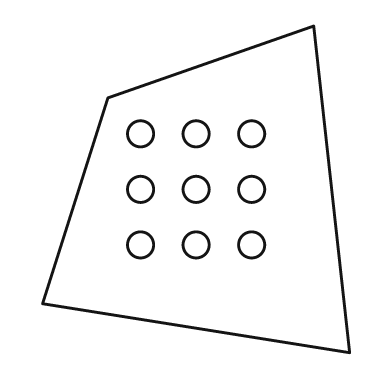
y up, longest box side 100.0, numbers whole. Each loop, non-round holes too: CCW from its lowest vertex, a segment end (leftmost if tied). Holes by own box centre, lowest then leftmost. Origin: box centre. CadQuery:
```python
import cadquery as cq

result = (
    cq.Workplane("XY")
    .moveTo(47.0, -50.0)
    .lineTo(36.0, 50.0)
    .lineTo(-27.0, 28.0)
    .lineTo(-47.0, -35.0)
    .close()
    .moveTo(-17.0, -17.0)
    .circle(4.0)
    .moveTo(0.0, -17.0)
    .circle(4.0)
    .moveTo(17.0, -17.0)
    .circle(4.0)
    .moveTo(-17.0, 0.0)
    .circle(4.0)
    .moveTo(0.0, 0.0)
    .circle(4.0)
    .moveTo(17.0, 0.0)
    .circle(4.0)
    .moveTo(-17.0, 17.0)
    .circle(4.0)
    .moveTo(0.0, 17.0)
    .circle(4.0)
    .moveTo(17.0, 17.0)
    .circle(4.0)
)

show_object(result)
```